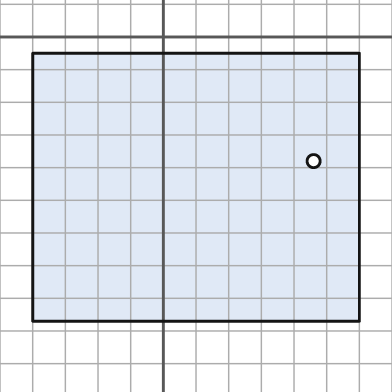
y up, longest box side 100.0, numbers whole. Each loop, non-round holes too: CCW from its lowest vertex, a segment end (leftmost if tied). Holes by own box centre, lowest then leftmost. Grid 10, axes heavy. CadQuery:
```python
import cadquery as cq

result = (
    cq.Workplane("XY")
    .moveTo(-40.0, -87.0)
    .lineTo(60.0, -87.0)
    .lineTo(60.0, -5.0)
    .lineTo(-40.0, -5.0)
    .close()
    .moveTo(46.0, -38.0)
    .circle(2.0)
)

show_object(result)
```